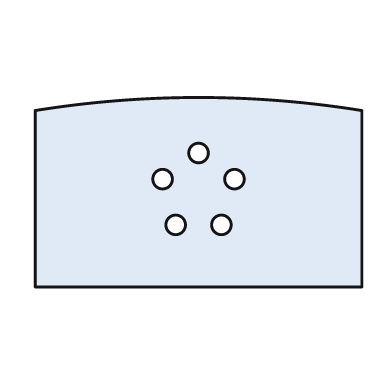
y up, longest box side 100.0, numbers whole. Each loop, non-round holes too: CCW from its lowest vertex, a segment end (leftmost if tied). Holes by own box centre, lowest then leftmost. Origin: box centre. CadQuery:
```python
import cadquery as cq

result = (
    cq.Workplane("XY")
    .moveTo(-50.0, -29.0)
    .lineTo(50.0, -29.0)
    .lineTo(50.0, 25.0)
    .threePointArc((0.0, 29.0), (-50.0, 25.0))
    .close()
    .moveTo(-7.0, -10.0)
    .circle(3.0)
    .moveTo(7.0, -10.0)
    .circle(3.0)
    .moveTo(-11.0, 4.0)
    .circle(3.0)
    .moveTo(11.0, 4.0)
    .circle(3.0)
    .moveTo(0.0, 12.0)
    .circle(3.0)
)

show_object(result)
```